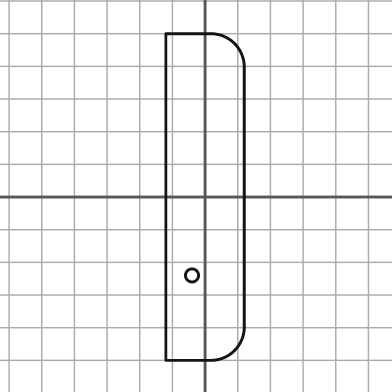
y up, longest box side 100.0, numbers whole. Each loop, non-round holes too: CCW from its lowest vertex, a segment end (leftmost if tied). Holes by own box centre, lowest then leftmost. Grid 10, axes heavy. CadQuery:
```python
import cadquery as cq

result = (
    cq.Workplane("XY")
    .moveTo(-12.0, -50.0)
    .lineTo(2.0, -50.0)
    .threePointArc((9.0, -47.0), (12.0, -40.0))
    .lineTo(12.0, 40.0)
    .threePointArc((9.0, 47.0), (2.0, 50.0))
    .lineTo(-12.0, 50.0)
    .close()
    .moveTo(-4.0, -24.0)
    .circle(2.0)
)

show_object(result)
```